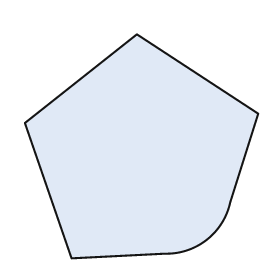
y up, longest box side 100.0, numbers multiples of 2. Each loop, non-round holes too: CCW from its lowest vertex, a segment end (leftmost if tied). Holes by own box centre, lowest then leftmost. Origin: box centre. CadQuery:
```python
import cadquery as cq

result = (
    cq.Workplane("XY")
    .moveTo(-30.0, -48.0)
    .lineTo(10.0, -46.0)
    .threePointArc((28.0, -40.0), (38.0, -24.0))
    .lineTo(50.0, 14.0)
    .lineTo(-2.0, 48.0)
    .lineTo(-50.0, 10.0)
    .close()
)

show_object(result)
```